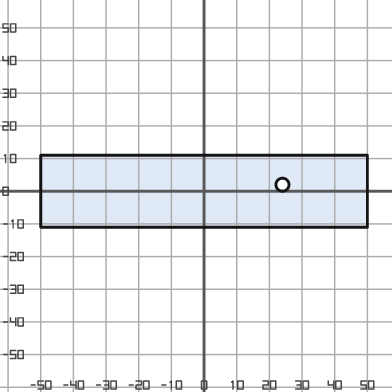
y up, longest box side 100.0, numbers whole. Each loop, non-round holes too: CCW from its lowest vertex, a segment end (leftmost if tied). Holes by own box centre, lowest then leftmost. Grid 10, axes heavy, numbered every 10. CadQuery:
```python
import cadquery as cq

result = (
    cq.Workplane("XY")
    .moveTo(-50.0, -11.0)
    .lineTo(50.0, -11.0)
    .lineTo(50.0, 11.0)
    .lineTo(-50.0, 11.0)
    .close()
    .moveTo(24.0, 2.0)
    .circle(2.0)
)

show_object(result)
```